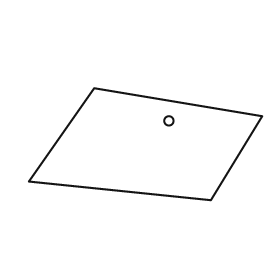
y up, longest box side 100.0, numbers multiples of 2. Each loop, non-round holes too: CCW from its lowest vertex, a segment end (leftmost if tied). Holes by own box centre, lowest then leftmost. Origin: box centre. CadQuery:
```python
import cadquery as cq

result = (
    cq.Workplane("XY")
    .moveTo(28.0, -24.0)
    .lineTo(50.0, 12.0)
    .lineTo(-22.0, 24.0)
    .lineTo(-50.0, -16.0)
    .close()
    .moveTo(10.0, 10.0)
    .circle(2.0)
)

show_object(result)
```